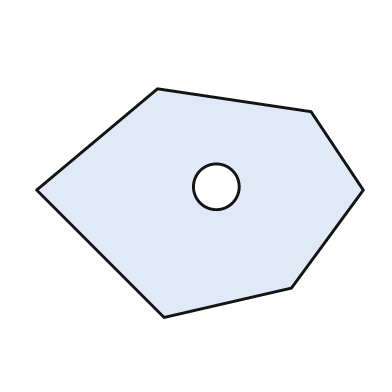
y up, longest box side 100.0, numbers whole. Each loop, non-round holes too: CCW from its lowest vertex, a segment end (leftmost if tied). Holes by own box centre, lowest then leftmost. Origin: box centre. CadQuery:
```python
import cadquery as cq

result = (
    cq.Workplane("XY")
    .moveTo(-11.0, -35.0)
    .lineTo(28.0, -26.0)
    .lineTo(50.0, 4.0)
    .lineTo(34.0, 28.0)
    .lineTo(-13.0, 35.0)
    .lineTo(-50.0, 4.0)
    .close()
    .moveTo(5.0, 5.0)
    .circle(7.0)
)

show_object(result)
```